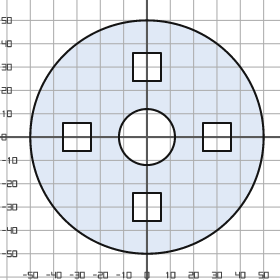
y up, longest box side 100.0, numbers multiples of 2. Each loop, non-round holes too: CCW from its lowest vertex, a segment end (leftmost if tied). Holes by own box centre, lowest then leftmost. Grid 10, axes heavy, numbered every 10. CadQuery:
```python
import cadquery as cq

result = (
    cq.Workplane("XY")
    .moveTo(0.0, 0.0)
    .circle(50.0)
    .moveTo(-6.0, -36.0)
    .lineTo(6.0, -36.0)
    .lineTo(6.0, -24.0)
    .lineTo(-6.0, -24.0)
    .close()
    .moveTo(-36.0, -6.0)
    .lineTo(-24.0, -6.0)
    .lineTo(-24.0, 6.0)
    .lineTo(-36.0, 6.0)
    .close()
    .moveTo(0.0, 0.0)
    .circle(12.0)
    .moveTo(24.0, -6.0)
    .lineTo(36.0, -6.0)
    .lineTo(36.0, 6.0)
    .lineTo(24.0, 6.0)
    .close()
    .moveTo(-6.0, 24.0)
    .lineTo(6.0, 24.0)
    .lineTo(6.0, 36.0)
    .lineTo(-6.0, 36.0)
    .close()
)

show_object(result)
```